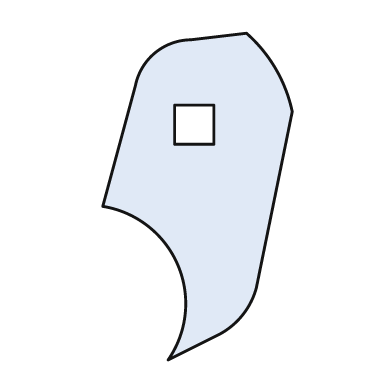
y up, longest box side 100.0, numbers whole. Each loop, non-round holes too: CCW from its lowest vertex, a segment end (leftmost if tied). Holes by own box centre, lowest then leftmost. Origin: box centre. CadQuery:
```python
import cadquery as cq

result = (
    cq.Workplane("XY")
    .moveTo(-9.0, -50.0)
    .lineTo(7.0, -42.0)
    .threePointArc((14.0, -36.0), (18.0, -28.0))
    .lineTo(29.0, 26.0)
    .threePointArc((24.0, 39.0), (15.0, 50.0))
    .lineTo(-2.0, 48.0)
    .threePointArc((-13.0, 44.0), (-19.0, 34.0))
    .lineTo(-29.0, -3.0)
    .threePointArc((-6.0, -21.0), (-9.0, -50.0))
    .close()
    .moveTo(-7.0, 16.0)
    .lineTo(5.0, 16.0)
    .lineTo(5.0, 28.0)
    .lineTo(-7.0, 28.0)
    .close()
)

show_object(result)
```